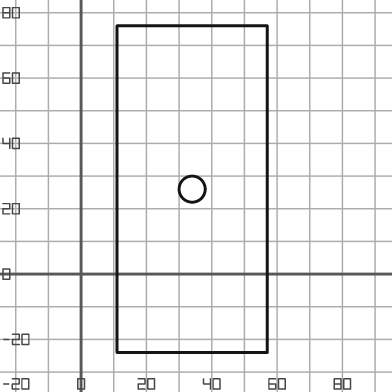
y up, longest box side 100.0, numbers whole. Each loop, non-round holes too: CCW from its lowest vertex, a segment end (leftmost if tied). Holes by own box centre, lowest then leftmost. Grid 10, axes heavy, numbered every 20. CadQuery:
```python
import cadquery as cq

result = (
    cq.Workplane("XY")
    .moveTo(11.0, -24.0)
    .lineTo(57.0, -24.0)
    .lineTo(57.0, 76.0)
    .lineTo(11.0, 76.0)
    .close()
    .moveTo(34.0, 26.0)
    .circle(4.0)
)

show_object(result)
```